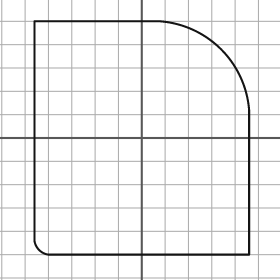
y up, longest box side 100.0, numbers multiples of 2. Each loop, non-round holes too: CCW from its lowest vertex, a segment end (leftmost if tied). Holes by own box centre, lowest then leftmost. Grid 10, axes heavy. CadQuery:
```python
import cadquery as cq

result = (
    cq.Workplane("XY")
    .moveTo(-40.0, -50.0)
    .lineTo(46.0, -50.0)
    .lineTo(46.0, 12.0)
    .threePointArc((34.0, 38.0), (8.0, 50.0))
    .lineTo(-46.0, 50.0)
    .lineTo(-46.0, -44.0)
    .threePointArc((-44.0, -48.0), (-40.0, -50.0))
    .close()
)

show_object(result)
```